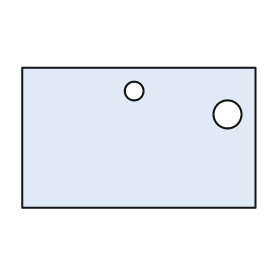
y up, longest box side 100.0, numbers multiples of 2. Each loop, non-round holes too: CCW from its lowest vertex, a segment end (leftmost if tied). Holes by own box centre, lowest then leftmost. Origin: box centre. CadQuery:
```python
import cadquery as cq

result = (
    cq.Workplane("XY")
    .moveTo(-50.0, -30.0)
    .lineTo(50.0, -30.0)
    .lineTo(50.0, 30.0)
    .lineTo(-50.0, 30.0)
    .close()
    .moveTo(38.0, 10.0)
    .circle(6.0)
    .moveTo(-2.0, 20.0)
    .circle(4.0)
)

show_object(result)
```